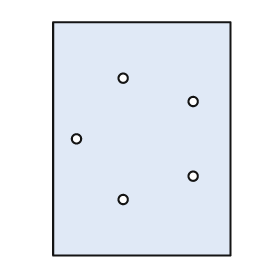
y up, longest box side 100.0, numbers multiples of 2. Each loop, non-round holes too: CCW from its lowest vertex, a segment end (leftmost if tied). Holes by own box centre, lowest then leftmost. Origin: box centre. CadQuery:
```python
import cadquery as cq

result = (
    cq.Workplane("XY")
    .moveTo(-38.0, -50.0)
    .lineTo(38.0, -50.0)
    .lineTo(38.0, 50.0)
    .lineTo(-38.0, 50.0)
    .close()
    .moveTo(-8.0, -26.0)
    .circle(2.0)
    .moveTo(22.0, -16.0)
    .circle(2.0)
    .moveTo(-28.0, 0.0)
    .circle(2.0)
    .moveTo(22.0, 16.0)
    .circle(2.0)
    .moveTo(-8.0, 26.0)
    .circle(2.0)
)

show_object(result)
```